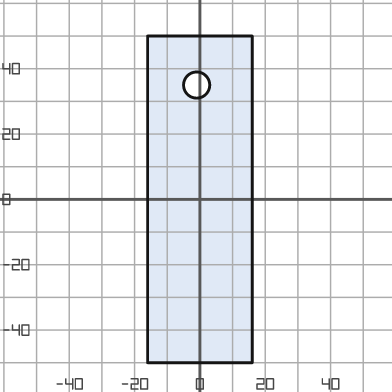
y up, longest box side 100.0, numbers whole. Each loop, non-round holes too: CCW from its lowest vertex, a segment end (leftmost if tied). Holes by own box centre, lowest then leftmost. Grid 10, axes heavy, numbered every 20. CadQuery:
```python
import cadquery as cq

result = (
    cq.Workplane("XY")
    .moveTo(-16.0, -50.0)
    .lineTo(16.0, -50.0)
    .lineTo(16.0, 50.0)
    .lineTo(-16.0, 50.0)
    .close()
    .moveTo(-1.0, 35.0)
    .circle(4.0)
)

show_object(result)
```